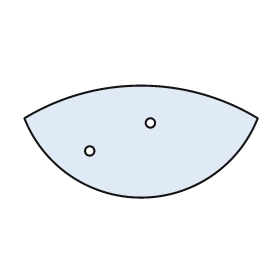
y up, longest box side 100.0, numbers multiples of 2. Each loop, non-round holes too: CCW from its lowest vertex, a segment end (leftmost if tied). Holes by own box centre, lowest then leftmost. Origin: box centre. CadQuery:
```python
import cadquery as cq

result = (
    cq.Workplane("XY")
    .moveTo(-50.0, 10.0)
    .threePointArc((0.0, -24.0), (50.0, 10.0))
    .threePointArc((0.0, 24.0), (-50.0, 10.0))
    .close()
    .moveTo(-22.0, -4.0)
    .circle(2.0)
    .moveTo(4.0, 8.0)
    .circle(2.0)
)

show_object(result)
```